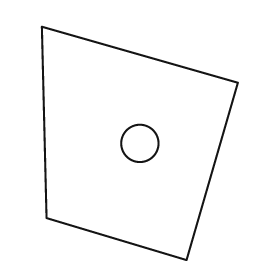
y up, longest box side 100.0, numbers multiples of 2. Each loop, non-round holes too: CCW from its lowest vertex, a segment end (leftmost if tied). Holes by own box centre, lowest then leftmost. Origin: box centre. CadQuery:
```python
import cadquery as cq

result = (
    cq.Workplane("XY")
    .moveTo(20.0, -50.0)
    .lineTo(42.0, 26.0)
    .lineTo(-42.0, 50.0)
    .lineTo(-40.0, -32.0)
    .close()
    .moveTo(0.0, 0.0)
    .circle(8.0)
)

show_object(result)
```